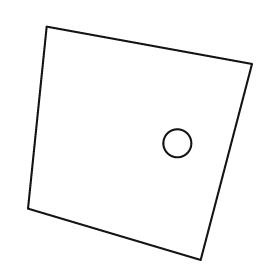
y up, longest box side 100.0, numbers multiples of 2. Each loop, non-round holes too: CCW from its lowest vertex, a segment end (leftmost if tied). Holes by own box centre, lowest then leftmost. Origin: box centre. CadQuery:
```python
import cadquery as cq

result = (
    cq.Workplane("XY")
    .moveTo(26.0, -50.0)
    .lineTo(48.0, 34.0)
    .lineTo(-40.0, 50.0)
    .lineTo(-48.0, -28.0)
    .close()
    .moveTo(16.0, 0.0)
    .circle(6.0)
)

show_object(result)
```